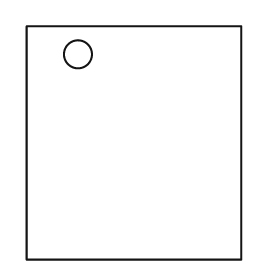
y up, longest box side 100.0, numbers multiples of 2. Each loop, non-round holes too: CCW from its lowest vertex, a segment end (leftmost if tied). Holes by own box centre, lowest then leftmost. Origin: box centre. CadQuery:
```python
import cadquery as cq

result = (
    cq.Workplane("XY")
    .moveTo(-46.0, -50.0)
    .lineTo(46.0, -50.0)
    .lineTo(46.0, 50.0)
    .lineTo(-46.0, 50.0)
    .close()
    .moveTo(-24.0, 38.0)
    .circle(6.0)
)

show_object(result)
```